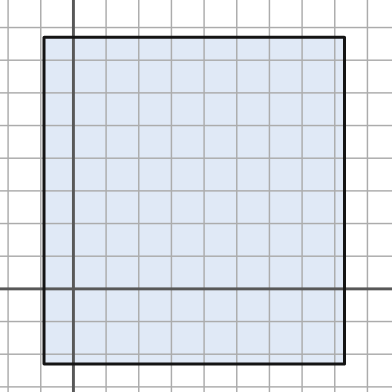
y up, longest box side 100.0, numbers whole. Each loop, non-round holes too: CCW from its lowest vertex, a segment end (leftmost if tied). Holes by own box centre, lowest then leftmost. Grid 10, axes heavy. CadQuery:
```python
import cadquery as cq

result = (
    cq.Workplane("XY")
    .moveTo(-9.0, -23.0)
    .lineTo(83.0, -23.0)
    .lineTo(83.0, 77.0)
    .lineTo(-9.0, 77.0)
    .close()
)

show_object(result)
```